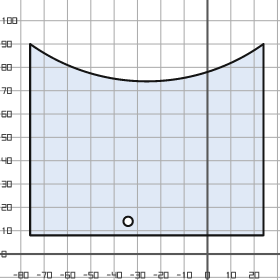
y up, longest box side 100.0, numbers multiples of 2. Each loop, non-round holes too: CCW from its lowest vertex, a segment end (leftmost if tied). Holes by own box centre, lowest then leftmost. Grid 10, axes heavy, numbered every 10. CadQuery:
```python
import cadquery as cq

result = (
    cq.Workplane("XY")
    .moveTo(-76.0, 8.0)
    .lineTo(24.0, 8.0)
    .lineTo(24.0, 90.0)
    .threePointArc((-26.0, 74.0), (-76.0, 90.0))
    .close()
    .moveTo(-34.0, 14.0)
    .circle(2.0)
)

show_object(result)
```